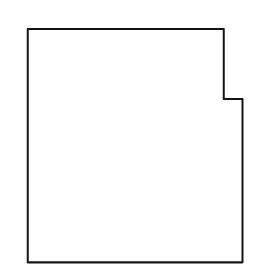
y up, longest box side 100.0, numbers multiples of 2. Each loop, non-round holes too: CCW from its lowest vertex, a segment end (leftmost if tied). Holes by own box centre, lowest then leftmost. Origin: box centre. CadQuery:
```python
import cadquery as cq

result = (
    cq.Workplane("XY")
    .moveTo(-46.0, -50.0)
    .lineTo(46.0, -50.0)
    .lineTo(46.0, 20.0)
    .lineTo(38.0, 20.0)
    .lineTo(38.0, 50.0)
    .lineTo(-46.0, 50.0)
    .close()
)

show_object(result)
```